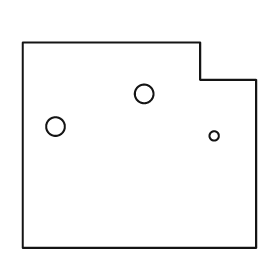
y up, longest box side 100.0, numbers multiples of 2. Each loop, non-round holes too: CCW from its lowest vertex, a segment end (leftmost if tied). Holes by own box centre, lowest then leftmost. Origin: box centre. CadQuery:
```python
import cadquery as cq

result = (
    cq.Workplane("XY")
    .moveTo(-50.0, -44.0)
    .lineTo(50.0, -44.0)
    .lineTo(50.0, 28.0)
    .lineTo(26.0, 28.0)
    .lineTo(26.0, 44.0)
    .lineTo(-50.0, 44.0)
    .close()
    .moveTo(32.0, 4.0)
    .circle(2.0)
    .moveTo(-36.0, 8.0)
    .circle(4.0)
    .moveTo(2.0, 22.0)
    .circle(4.0)
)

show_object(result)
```